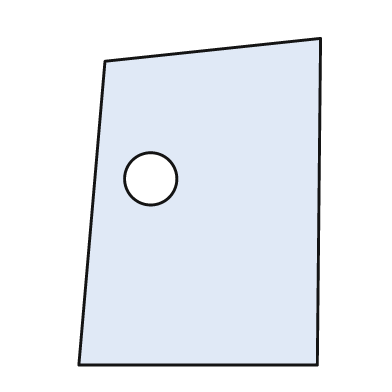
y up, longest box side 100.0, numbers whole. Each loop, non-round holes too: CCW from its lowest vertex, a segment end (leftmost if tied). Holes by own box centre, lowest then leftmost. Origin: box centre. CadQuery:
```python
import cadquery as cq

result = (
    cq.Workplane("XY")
    .moveTo(-37.0, -50.0)
    .lineTo(36.0, -50.0)
    .lineTo(37.0, 50.0)
    .lineTo(-29.0, 43.0)
    .close()
    .moveTo(-15.0, 7.0)
    .circle(8.0)
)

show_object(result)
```